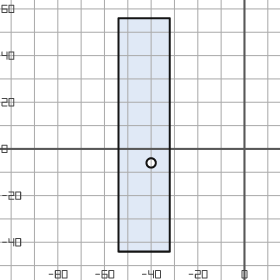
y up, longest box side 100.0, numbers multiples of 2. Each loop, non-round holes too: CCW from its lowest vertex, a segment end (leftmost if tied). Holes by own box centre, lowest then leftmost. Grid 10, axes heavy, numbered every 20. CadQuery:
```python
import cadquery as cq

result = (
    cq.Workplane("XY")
    .moveTo(-54.0, -44.0)
    .lineTo(-32.0, -44.0)
    .lineTo(-32.0, 56.0)
    .lineTo(-54.0, 56.0)
    .close()
    .moveTo(-40.0, -6.0)
    .circle(2.0)
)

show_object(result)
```